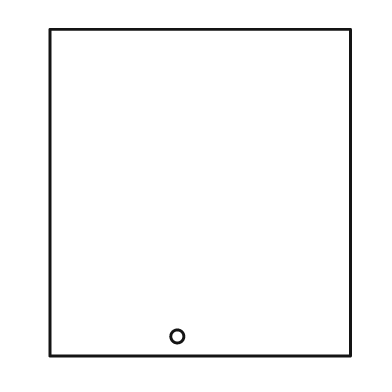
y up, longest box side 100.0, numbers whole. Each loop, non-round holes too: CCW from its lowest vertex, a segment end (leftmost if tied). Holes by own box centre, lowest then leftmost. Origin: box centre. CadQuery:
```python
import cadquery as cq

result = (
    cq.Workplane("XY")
    .moveTo(-46.0, -50.0)
    .lineTo(46.0, -50.0)
    .lineTo(46.0, 50.0)
    .lineTo(-46.0, 50.0)
    .close()
    .moveTo(-7.0, -44.0)
    .circle(2.0)
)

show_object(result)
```